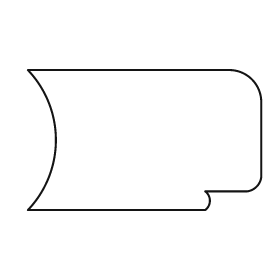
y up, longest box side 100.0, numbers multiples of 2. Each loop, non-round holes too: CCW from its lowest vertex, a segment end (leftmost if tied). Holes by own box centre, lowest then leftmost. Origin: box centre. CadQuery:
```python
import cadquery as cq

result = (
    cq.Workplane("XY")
    .moveTo(-50.0, -30.0)
    .lineTo(26.0, -30.0)
    .threePointArc((28.0, -26.0), (26.0, -22.0))
    .lineTo(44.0, -22.0)
    .threePointArc((48.0, -20.0), (50.0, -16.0))
    .lineTo(50.0, 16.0)
    .threePointArc((46.0, 26.0), (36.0, 30.0))
    .lineTo(-50.0, 30.0)
    .threePointArc((-38.0, 0.0), (-50.0, -30.0))
    .close()
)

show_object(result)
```